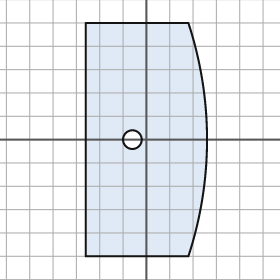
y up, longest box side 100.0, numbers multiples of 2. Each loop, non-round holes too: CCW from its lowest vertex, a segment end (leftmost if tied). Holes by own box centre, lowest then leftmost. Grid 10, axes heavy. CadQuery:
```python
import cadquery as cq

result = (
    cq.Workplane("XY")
    .moveTo(-26.0, -50.0)
    .lineTo(18.0, -50.0)
    .threePointArc((26.0, 0.0), (18.0, 50.0))
    .lineTo(-26.0, 50.0)
    .close()
    .moveTo(-6.0, 0.0)
    .circle(4.0)
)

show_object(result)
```